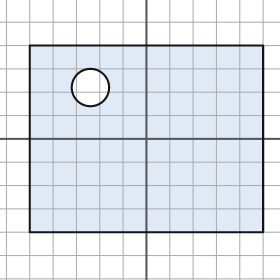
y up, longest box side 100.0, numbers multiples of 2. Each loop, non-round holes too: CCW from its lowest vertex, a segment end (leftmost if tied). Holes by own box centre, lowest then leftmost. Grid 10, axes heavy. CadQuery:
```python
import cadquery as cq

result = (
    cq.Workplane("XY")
    .moveTo(-50.0, -40.0)
    .lineTo(50.0, -40.0)
    .lineTo(50.0, 40.0)
    .lineTo(-50.0, 40.0)
    .close()
    .moveTo(-24.0, 22.0)
    .circle(8.0)
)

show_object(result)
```